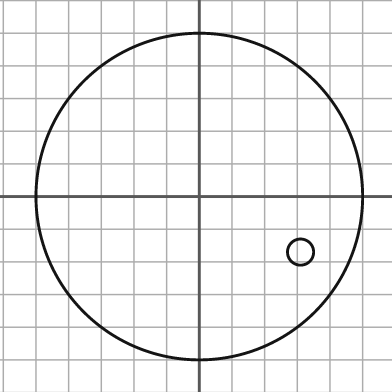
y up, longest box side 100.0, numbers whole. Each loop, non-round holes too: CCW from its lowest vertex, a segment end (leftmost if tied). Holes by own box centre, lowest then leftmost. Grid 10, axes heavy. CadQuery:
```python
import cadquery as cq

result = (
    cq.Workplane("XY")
    .moveTo(0.0, 0.0)
    .circle(50.0)
    .moveTo(31.0, -17.0)
    .circle(4.0)
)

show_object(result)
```